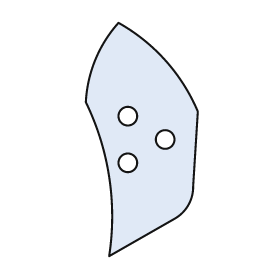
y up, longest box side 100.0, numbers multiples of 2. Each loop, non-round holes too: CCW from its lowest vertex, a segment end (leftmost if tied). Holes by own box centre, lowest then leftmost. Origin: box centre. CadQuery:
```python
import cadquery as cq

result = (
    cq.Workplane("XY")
    .moveTo(-14.0, -50.0)
    .lineTo(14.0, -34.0)
    .threePointArc((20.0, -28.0), (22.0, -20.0))
    .lineTo(24.0, 12.0)
    .threePointArc((10.0, 34.0), (-10.0, 50.0))
    .threePointArc((-20.0, 34.0), (-24.0, 16.0))
    .threePointArc((-14.0, -16.0), (-14.0, -50.0))
    .close()
    .moveTo(-6.0, -10.0)
    .circle(4.0)
    .moveTo(10.0, 0.0)
    .circle(4.0)
    .moveTo(-6.0, 10.0)
    .circle(4.0)
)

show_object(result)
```